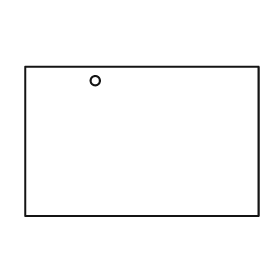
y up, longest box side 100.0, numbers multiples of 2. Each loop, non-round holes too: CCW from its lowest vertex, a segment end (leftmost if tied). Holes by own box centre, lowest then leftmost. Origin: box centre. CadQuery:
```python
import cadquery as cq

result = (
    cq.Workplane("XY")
    .moveTo(-50.0, -32.0)
    .lineTo(50.0, -32.0)
    .lineTo(50.0, 32.0)
    .lineTo(-50.0, 32.0)
    .close()
    .moveTo(-20.0, 26.0)
    .circle(2.0)
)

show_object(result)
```